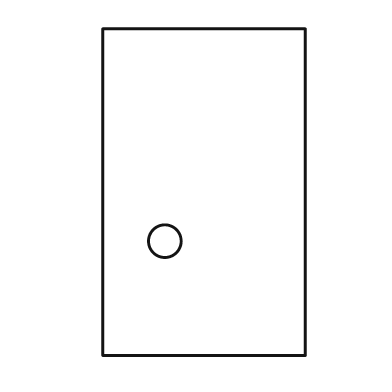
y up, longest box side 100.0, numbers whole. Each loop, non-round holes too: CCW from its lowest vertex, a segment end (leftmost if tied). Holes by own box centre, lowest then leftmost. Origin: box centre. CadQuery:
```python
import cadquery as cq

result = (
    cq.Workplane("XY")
    .moveTo(-31.0, -50.0)
    .lineTo(31.0, -50.0)
    .lineTo(31.0, 50.0)
    .lineTo(-31.0, 50.0)
    .close()
    .moveTo(-12.0, -15.0)
    .circle(5.0)
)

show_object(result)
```